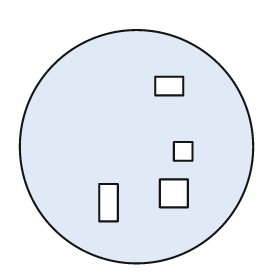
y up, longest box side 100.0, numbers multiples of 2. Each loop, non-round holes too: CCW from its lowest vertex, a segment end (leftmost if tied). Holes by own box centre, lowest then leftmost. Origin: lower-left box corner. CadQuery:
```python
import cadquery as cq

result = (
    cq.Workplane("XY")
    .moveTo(50.0, 50.0)
    .circle(50.0)
    .moveTo(34.0, 18.0)
    .lineTo(42.0, 18.0)
    .lineTo(42.0, 34.0)
    .lineTo(34.0, 34.0)
    .close()
    .moveTo(60.0, 24.0)
    .lineTo(72.0, 24.0)
    .lineTo(72.0, 36.0)
    .lineTo(60.0, 36.0)
    .close()
    .moveTo(66.0, 44.0)
    .lineTo(74.0, 44.0)
    .lineTo(74.0, 52.0)
    .lineTo(66.0, 52.0)
    .close()
    .moveTo(58.0, 72.0)
    .lineTo(70.0, 72.0)
    .lineTo(70.0, 80.0)
    .lineTo(58.0, 80.0)
    .close()
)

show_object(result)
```